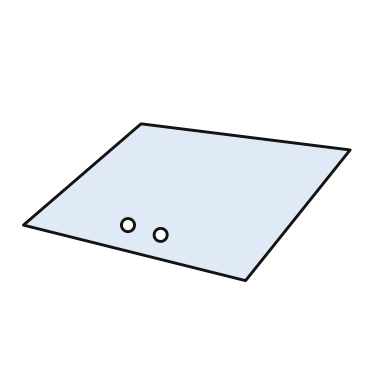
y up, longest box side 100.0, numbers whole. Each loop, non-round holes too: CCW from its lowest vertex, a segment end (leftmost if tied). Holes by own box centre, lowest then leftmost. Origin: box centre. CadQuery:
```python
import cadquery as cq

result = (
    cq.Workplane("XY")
    .moveTo(18.0, -24.0)
    .lineTo(50.0, 16.0)
    .lineTo(-14.0, 24.0)
    .lineTo(-50.0, -7.0)
    .close()
    .moveTo(-8.0, -10.0)
    .circle(2.0)
    .moveTo(-18.0, -7.0)
    .circle(2.0)
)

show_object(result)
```